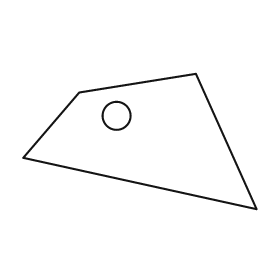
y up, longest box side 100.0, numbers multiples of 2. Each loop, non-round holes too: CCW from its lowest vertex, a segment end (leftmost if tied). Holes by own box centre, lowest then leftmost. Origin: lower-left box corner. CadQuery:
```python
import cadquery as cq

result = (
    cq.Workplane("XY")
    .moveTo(100.0, 0.0)
    .lineTo(74.0, 58.0)
    .lineTo(24.0, 50.0)
    .lineTo(0.0, 22.0)
    .close()
    .moveTo(40.0, 40.0)
    .circle(6.0)
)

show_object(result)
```